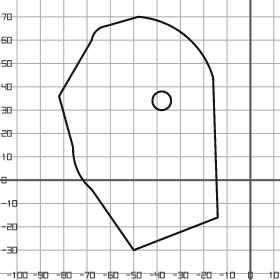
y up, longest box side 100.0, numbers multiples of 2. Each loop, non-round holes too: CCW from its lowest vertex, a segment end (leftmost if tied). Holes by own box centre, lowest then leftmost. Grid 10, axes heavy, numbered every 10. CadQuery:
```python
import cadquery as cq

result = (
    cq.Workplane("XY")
    .moveTo(-50.0, -30.0)
    .lineTo(-14.0, -16.0)
    .lineTo(-16.0, 44.0)
    .threePointArc((-28.0, 62.0), (-48.0, 70.0))
    .lineTo(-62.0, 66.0)
    .threePointArc((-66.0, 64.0), (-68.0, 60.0))
    .lineTo(-82.0, 36.0)
    .lineTo(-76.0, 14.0)
    .threePointArc((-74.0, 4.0), (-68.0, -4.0))
    .close()
    .moveTo(-38.0, 34.0)
    .circle(4.0)
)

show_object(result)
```